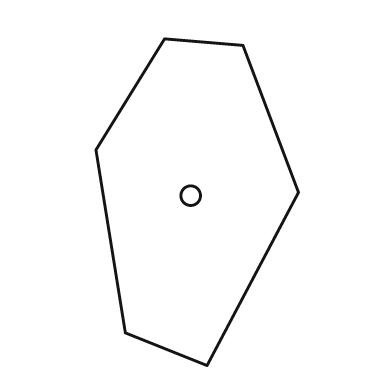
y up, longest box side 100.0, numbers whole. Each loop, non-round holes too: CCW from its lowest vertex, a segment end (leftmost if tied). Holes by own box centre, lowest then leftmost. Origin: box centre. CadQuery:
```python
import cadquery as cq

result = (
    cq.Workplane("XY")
    .moveTo(3.0, -50.0)
    .lineTo(31.0, 3.0)
    .lineTo(14.0, 48.0)
    .lineTo(-10.0, 50.0)
    .lineTo(-31.0, 16.0)
    .lineTo(-22.0, -40.0)
    .close()
    .moveTo(-2.0, 2.0)
    .circle(3.0)
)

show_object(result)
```